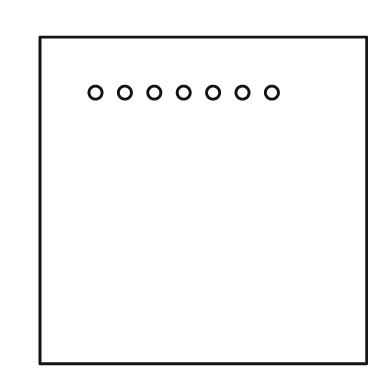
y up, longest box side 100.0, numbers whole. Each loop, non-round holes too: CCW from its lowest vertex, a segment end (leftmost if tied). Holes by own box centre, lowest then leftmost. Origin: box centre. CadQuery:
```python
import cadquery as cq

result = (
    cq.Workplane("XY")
    .moveTo(-50.0, -50.0)
    .lineTo(50.0, -50.0)
    .lineTo(50.0, 50.0)
    .lineTo(-50.0, 50.0)
    .close()
    .moveTo(-33.0, 33.0)
    .circle(2.0)
    .moveTo(-24.0, 33.0)
    .circle(2.0)
    .moveTo(-15.0, 33.0)
    .circle(2.0)
    .moveTo(-6.0, 33.0)
    .circle(2.0)
    .moveTo(3.0, 33.0)
    .circle(2.0)
    .moveTo(12.0, 33.0)
    .circle(2.0)
    .moveTo(21.0, 33.0)
    .circle(2.0)
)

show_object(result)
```